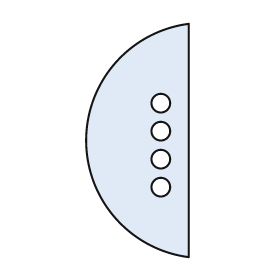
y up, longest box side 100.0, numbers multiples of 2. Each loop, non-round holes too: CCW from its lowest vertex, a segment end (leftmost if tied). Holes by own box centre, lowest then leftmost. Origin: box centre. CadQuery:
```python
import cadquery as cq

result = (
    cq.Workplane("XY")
    .moveTo(22.0, -50.0)
    .lineTo(22.0, 50.0)
    .threePointArc((-22.0, 0.0), (22.0, -50.0))
    .close()
    .moveTo(10.0, -20.0)
    .circle(4.0)
    .moveTo(10.0, -8.0)
    .circle(4.0)
    .moveTo(10.0, 4.0)
    .circle(4.0)
    .moveTo(10.0, 16.0)
    .circle(4.0)
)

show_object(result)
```